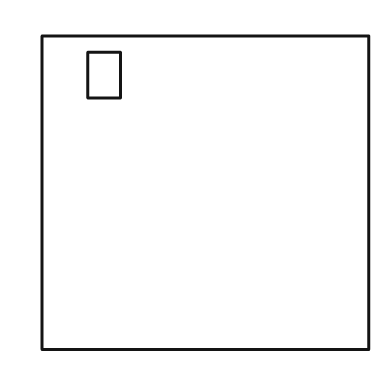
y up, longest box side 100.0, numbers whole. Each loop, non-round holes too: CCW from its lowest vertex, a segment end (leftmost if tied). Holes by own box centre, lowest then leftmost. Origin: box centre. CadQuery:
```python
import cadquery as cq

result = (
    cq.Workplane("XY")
    .moveTo(-50.0, -48.0)
    .lineTo(50.0, -48.0)
    .lineTo(50.0, 48.0)
    .lineTo(-50.0, 48.0)
    .close()
    .moveTo(-36.0, 29.0)
    .lineTo(-26.0, 29.0)
    .lineTo(-26.0, 43.0)
    .lineTo(-36.0, 43.0)
    .close()
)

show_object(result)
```